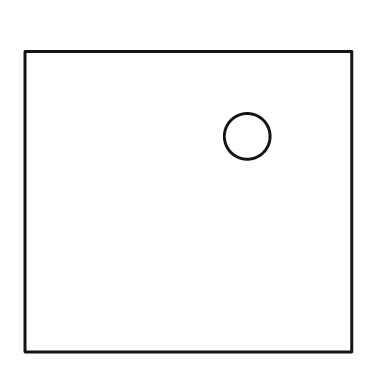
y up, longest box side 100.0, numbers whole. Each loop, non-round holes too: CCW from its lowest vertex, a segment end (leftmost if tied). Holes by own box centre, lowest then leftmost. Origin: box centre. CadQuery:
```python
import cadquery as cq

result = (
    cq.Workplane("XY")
    .moveTo(-50.0, -46.0)
    .lineTo(50.0, -46.0)
    .lineTo(50.0, 46.0)
    .lineTo(-50.0, 46.0)
    .close()
    .moveTo(18.0, 20.0)
    .circle(7.0)
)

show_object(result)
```